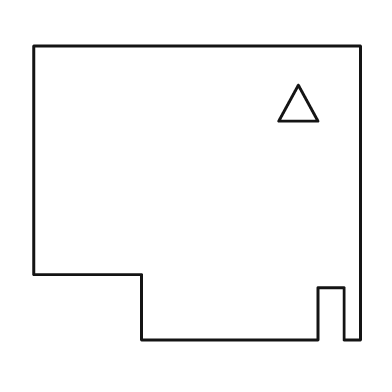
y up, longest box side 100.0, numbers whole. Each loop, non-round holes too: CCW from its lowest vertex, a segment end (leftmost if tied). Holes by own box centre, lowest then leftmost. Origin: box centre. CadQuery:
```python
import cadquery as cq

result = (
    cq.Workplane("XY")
    .moveTo(-17.0, -45.0)
    .lineTo(37.0, -45.0)
    .lineTo(37.0, -29.0)
    .lineTo(45.0, -29.0)
    .lineTo(45.0, -45.0)
    .lineTo(50.0, -45.0)
    .lineTo(50.0, 45.0)
    .lineTo(-50.0, 45.0)
    .lineTo(-50.0, -25.0)
    .lineTo(-17.0, -25.0)
    .close()
    .moveTo(25.0, 22.0)
    .lineTo(37.0, 22.0)
    .lineTo(31.0, 33.0)
    .close()
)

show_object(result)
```